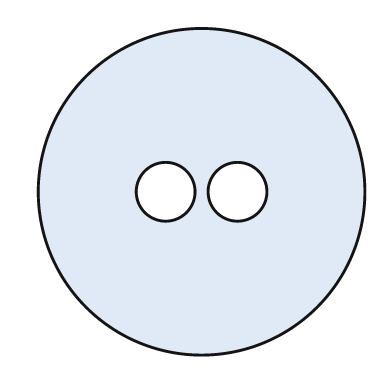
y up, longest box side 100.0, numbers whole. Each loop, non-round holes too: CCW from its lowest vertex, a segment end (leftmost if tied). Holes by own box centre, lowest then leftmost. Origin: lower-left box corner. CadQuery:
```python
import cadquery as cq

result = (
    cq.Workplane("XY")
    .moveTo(50.0, 50.0)
    .circle(50.0)
    .moveTo(39.0, 50.0)
    .circle(9.0)
    .moveTo(61.0, 50.0)
    .circle(9.0)
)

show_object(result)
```